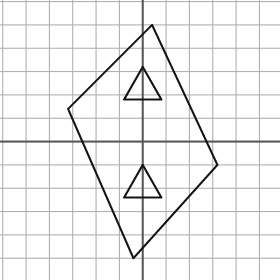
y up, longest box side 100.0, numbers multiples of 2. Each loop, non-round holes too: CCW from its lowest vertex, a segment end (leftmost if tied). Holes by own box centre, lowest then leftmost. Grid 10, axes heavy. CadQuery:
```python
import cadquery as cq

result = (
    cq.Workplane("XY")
    .moveTo(-4.0, -50.0)
    .lineTo(32.0, -10.0)
    .lineTo(4.0, 50.0)
    .lineTo(-32.0, 14.0)
    .close()
    .moveTo(-8.0, -24.0)
    .lineTo(8.0, -24.0)
    .lineTo(0.0, -10.0)
    .close()
    .moveTo(-8.0, 18.0)
    .lineTo(8.0, 18.0)
    .lineTo(0.0, 32.0)
    .close()
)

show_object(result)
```